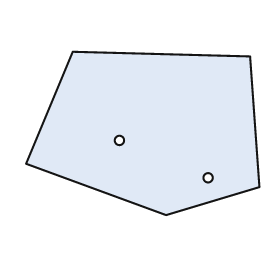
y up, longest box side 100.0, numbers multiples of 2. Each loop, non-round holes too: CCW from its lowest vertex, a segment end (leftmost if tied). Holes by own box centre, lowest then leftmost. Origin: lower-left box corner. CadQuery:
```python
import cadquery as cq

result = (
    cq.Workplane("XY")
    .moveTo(60.0, 0.0)
    .lineTo(100.0, 12.0)
    .lineTo(96.0, 68.0)
    .lineTo(20.0, 70.0)
    .lineTo(0.0, 22.0)
    .close()
    .moveTo(78.0, 16.0)
    .circle(2.0)
    .moveTo(40.0, 32.0)
    .circle(2.0)
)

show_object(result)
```